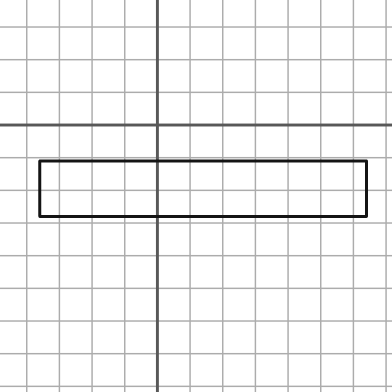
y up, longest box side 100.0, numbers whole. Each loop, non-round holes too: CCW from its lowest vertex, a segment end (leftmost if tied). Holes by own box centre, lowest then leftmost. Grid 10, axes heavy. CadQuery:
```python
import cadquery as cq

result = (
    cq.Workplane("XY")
    .moveTo(-36.0, -28.0)
    .lineTo(64.0, -28.0)
    .lineTo(64.0, -11.0)
    .lineTo(-36.0, -11.0)
    .close()
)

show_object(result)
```